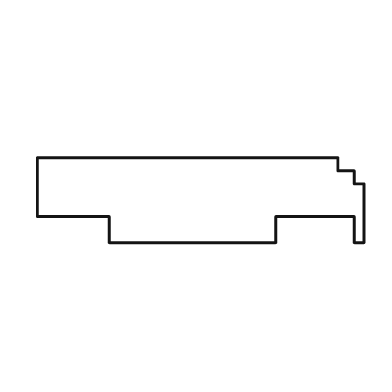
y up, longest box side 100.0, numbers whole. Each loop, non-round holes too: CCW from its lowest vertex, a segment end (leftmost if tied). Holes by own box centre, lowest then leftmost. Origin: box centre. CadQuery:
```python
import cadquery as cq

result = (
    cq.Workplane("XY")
    .moveTo(-28.0, -13.0)
    .lineTo(23.0, -13.0)
    .lineTo(23.0, -5.0)
    .lineTo(47.0, -5.0)
    .lineTo(47.0, -13.0)
    .lineTo(50.0, -13.0)
    .lineTo(50.0, 5.0)
    .lineTo(47.0, 5.0)
    .lineTo(47.0, 9.0)
    .lineTo(42.0, 9.0)
    .lineTo(42.0, 13.0)
    .lineTo(-50.0, 13.0)
    .lineTo(-50.0, -5.0)
    .lineTo(-28.0, -5.0)
    .close()
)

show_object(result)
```